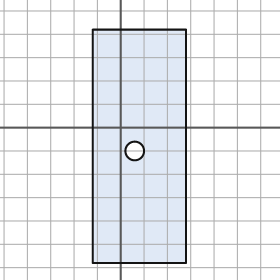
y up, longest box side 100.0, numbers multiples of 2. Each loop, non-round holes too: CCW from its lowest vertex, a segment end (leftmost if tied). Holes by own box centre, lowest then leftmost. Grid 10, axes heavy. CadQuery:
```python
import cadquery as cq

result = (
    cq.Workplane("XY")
    .moveTo(-12.0, -58.0)
    .lineTo(28.0, -58.0)
    .lineTo(28.0, 42.0)
    .lineTo(-12.0, 42.0)
    .close()
    .moveTo(6.0, -10.0)
    .circle(4.0)
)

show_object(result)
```